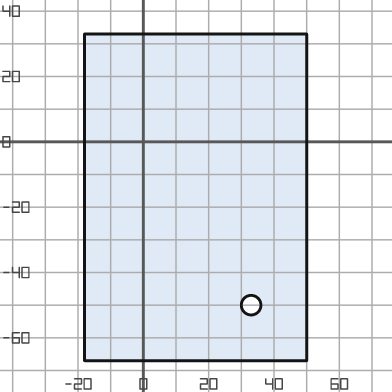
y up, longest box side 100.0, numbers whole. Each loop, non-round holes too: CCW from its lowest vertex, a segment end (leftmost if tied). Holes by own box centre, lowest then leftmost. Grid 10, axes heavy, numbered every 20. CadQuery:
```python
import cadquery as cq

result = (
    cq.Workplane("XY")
    .moveTo(-18.0, -67.0)
    .lineTo(50.0, -67.0)
    .lineTo(50.0, 33.0)
    .lineTo(-18.0, 33.0)
    .close()
    .moveTo(33.0, -50.0)
    .circle(3.0)
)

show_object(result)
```